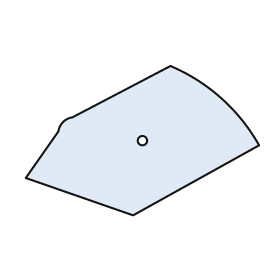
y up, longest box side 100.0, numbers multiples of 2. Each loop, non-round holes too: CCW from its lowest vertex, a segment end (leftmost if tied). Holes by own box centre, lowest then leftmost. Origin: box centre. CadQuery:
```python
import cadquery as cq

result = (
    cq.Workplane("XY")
    .moveTo(-4.0, -32.0)
    .lineTo(50.0, -2.0)
    .threePointArc((34.0, 18.0), (12.0, 32.0))
    .lineTo(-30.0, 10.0)
    .threePointArc((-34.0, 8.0), (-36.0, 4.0))
    .lineTo(-50.0, -16.0)
    .close()
    .moveTo(0.0, 0.0)
    .circle(2.0)
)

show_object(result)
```